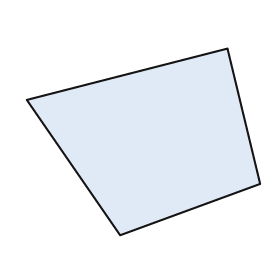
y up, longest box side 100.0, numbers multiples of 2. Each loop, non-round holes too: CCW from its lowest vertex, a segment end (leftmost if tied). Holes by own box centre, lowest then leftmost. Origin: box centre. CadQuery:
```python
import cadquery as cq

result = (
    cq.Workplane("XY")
    .moveTo(-10.0, -40.0)
    .lineTo(50.0, -18.0)
    .lineTo(36.0, 40.0)
    .lineTo(-50.0, 18.0)
    .close()
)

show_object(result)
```